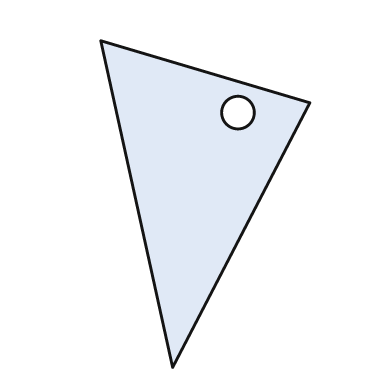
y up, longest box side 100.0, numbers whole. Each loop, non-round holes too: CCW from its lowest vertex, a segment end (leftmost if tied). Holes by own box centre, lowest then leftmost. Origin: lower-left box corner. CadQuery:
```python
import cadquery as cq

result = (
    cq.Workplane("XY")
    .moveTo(22.0, 0.0)
    .lineTo(64.0, 81.0)
    .lineTo(0.0, 100.0)
    .close()
    .moveTo(42.0, 78.0)
    .circle(5.0)
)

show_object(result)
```